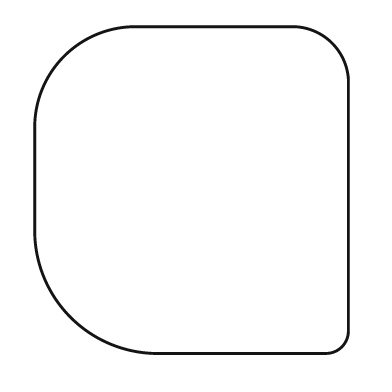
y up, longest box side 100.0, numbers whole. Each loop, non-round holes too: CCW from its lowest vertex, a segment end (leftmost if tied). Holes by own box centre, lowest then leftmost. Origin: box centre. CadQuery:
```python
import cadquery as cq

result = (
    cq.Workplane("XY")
    .moveTo(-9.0, -50.0)
    .lineTo(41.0, -50.0)
    .threePointArc((46.0, -48.0), (48.0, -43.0))
    .lineTo(48.0, 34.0)
    .threePointArc((43.0, 45.0), (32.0, 50.0))
    .lineTo(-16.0, 50.0)
    .threePointArc((-39.0, 41.0), (-48.0, 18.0))
    .lineTo(-48.0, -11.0)
    .threePointArc((-37.0, -39.0), (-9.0, -50.0))
    .close()
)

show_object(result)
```